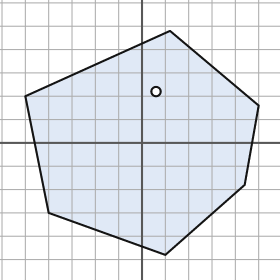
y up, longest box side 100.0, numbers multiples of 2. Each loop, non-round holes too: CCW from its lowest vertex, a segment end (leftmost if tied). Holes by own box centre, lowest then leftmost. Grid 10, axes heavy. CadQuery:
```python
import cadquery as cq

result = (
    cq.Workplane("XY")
    .moveTo(10.0, -48.0)
    .lineTo(44.0, -18.0)
    .lineTo(50.0, 16.0)
    .lineTo(12.0, 48.0)
    .lineTo(-50.0, 20.0)
    .lineTo(-40.0, -30.0)
    .close()
    .moveTo(6.0, 22.0)
    .circle(2.0)
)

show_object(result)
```